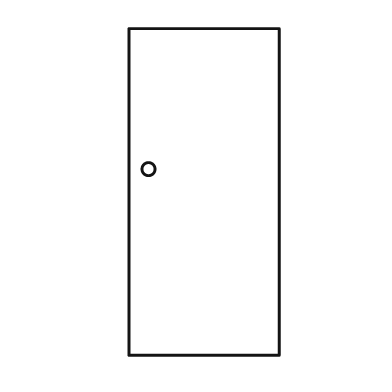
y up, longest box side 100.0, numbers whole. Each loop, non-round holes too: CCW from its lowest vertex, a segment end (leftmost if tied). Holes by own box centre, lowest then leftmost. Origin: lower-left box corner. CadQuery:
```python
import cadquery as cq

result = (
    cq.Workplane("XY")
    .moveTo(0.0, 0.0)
    .lineTo(46.0, 0.0)
    .lineTo(46.0, 100.0)
    .lineTo(0.0, 100.0)
    .close()
    .moveTo(6.0, 57.0)
    .circle(2.0)
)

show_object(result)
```